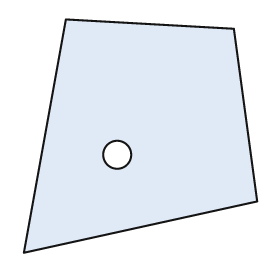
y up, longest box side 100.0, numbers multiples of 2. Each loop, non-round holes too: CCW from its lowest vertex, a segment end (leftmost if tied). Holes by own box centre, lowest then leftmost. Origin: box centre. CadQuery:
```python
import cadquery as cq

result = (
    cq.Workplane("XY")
    .moveTo(-50.0, -50.0)
    .lineTo(50.0, -28.0)
    .lineTo(40.0, 46.0)
    .lineTo(-32.0, 50.0)
    .close()
    .moveTo(-10.0, -8.0)
    .circle(6.0)
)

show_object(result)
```